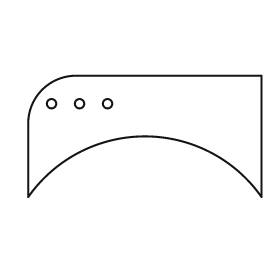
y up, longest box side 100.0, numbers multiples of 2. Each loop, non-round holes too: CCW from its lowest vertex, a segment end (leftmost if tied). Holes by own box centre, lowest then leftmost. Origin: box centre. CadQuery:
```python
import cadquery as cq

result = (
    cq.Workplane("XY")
    .moveTo(-50.0, -26.0)
    .threePointArc((0.0, 0.0), (50.0, -26.0))
    .lineTo(50.0, 26.0)
    .lineTo(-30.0, 26.0)
    .threePointArc((-44.0, 20.0), (-50.0, 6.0))
    .close()
    .moveTo(-40.0, 14.0)
    .circle(2.0)
    .moveTo(-28.0, 14.0)
    .circle(2.0)
    .moveTo(-16.0, 14.0)
    .circle(2.0)
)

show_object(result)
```